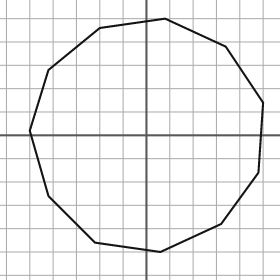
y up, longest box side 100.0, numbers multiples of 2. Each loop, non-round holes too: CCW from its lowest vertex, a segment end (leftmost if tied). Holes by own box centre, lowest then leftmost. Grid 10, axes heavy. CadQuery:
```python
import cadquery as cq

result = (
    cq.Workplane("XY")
    .moveTo(6.0, -50.0)
    .lineTo(32.0, -38.0)
    .lineTo(48.0, -16.0)
    .lineTo(50.0, 14.0)
    .lineTo(34.0, 38.0)
    .lineTo(8.0, 50.0)
    .lineTo(-20.0, 46.0)
    .lineTo(-42.0, 28.0)
    .lineTo(-50.0, 2.0)
    .lineTo(-42.0, -26.0)
    .lineTo(-22.0, -46.0)
    .close()
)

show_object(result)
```